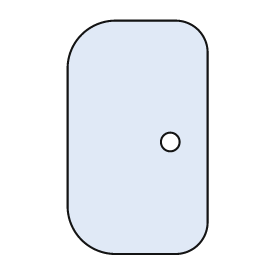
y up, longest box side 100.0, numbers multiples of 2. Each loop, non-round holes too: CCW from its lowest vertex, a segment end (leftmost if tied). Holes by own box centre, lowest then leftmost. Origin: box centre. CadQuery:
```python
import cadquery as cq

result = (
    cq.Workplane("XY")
    .moveTo(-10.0, -50.0)
    .lineTo(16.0, -50.0)
    .threePointArc((26.0, -46.0), (30.0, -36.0))
    .lineTo(30.0, 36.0)
    .threePointArc((26.0, 46.0), (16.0, 50.0))
    .lineTo(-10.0, 50.0)
    .threePointArc((-24.0, 44.0), (-30.0, 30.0))
    .lineTo(-30.0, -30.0)
    .threePointArc((-24.0, -44.0), (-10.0, -50.0))
    .close()
    .moveTo(14.0, -2.0)
    .circle(4.0)
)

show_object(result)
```